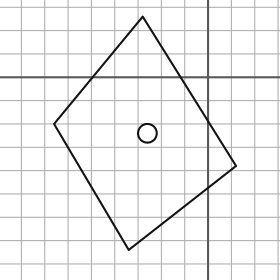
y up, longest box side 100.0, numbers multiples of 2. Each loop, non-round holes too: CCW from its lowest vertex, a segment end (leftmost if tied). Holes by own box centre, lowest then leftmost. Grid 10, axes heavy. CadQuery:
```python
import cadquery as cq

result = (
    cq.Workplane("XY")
    .moveTo(-34.0, -74.0)
    .lineTo(12.0, -38.0)
    .lineTo(-28.0, 26.0)
    .lineTo(-66.0, -20.0)
    .close()
    .moveTo(-26.0, -24.0)
    .circle(4.0)
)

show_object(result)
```